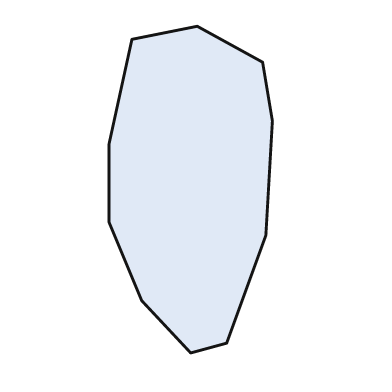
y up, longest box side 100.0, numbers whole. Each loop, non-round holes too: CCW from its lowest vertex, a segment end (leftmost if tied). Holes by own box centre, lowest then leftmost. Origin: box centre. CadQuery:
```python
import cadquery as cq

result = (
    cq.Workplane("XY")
    .moveTo(0.0, -50.0)
    .lineTo(11.0, -47.0)
    .lineTo(23.0, -14.0)
    .lineTo(25.0, 21.0)
    .lineTo(22.0, 39.0)
    .lineTo(2.0, 50.0)
    .lineTo(-18.0, 46.0)
    .lineTo(-25.0, 14.0)
    .lineTo(-25.0, -10.0)
    .lineTo(-15.0, -34.0)
    .close()
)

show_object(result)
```